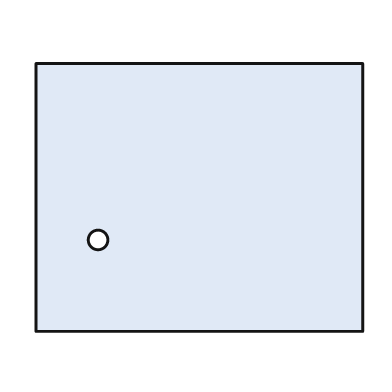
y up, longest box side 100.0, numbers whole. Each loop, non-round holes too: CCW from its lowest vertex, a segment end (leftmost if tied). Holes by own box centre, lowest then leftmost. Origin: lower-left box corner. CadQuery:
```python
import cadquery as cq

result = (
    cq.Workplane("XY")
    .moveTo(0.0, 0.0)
    .lineTo(100.0, 0.0)
    .lineTo(100.0, 82.0)
    .lineTo(0.0, 82.0)
    .close()
    .moveTo(19.0, 28.0)
    .circle(3.0)
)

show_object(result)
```